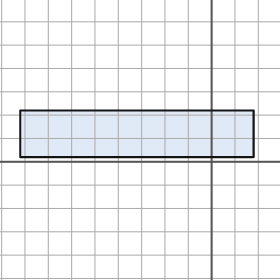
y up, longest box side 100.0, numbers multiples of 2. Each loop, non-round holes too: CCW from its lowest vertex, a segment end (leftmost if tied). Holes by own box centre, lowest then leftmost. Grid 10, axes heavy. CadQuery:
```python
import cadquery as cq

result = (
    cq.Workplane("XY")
    .moveTo(-82.0, 2.0)
    .lineTo(18.0, 2.0)
    .lineTo(18.0, 22.0)
    .lineTo(-82.0, 22.0)
    .close()
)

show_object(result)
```